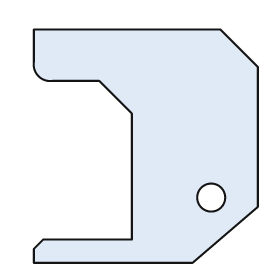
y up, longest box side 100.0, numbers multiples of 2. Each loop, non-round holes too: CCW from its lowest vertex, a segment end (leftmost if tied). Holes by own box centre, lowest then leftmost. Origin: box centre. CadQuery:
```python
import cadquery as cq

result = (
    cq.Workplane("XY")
    .moveTo(-48.0, -50.0)
    .lineTo(20.0, -50.0)
    .lineTo(48.0, -26.0)
    .lineTo(48.0, 34.0)
    .lineTo(32.0, 50.0)
    .lineTo(-48.0, 50.0)
    .lineTo(-48.0, 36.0)
    .threePointArc((-46.0, 30.0), (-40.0, 28.0))
    .lineTo(-20.0, 28.0)
    .lineTo(-6.0, 14.0)
    .lineTo(-6.0, -40.0)
    .lineTo(-44.0, -40.0)
    .lineTo(-48.0, -44.0)
    .close()
    .moveTo(28.0, -22.0)
    .circle(6.0)
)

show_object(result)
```